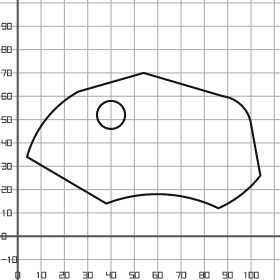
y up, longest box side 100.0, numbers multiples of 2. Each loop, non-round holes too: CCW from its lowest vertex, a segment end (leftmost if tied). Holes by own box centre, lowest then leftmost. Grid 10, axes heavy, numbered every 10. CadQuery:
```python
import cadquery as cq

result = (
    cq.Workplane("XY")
    .moveTo(86.0, 12.0)
    .threePointArc((96.0, 18.0), (104.0, 26.0))
    .lineTo(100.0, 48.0)
    .threePointArc((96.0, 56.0), (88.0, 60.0))
    .lineTo(54.0, 70.0)
    .lineTo(26.0, 62.0)
    .threePointArc((12.0, 50.0), (4.0, 34.0))
    .lineTo(38.0, 14.0)
    .threePointArc((62.0, 18.0), (86.0, 12.0))
    .close()
    .moveTo(40.0, 52.0)
    .circle(6.0)
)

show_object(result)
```